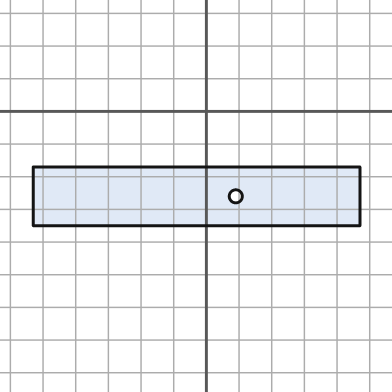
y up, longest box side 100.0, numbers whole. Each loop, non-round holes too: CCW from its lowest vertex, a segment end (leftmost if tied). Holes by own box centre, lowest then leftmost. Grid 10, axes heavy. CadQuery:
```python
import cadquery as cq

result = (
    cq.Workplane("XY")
    .moveTo(-53.0, -35.0)
    .lineTo(47.0, -35.0)
    .lineTo(47.0, -17.0)
    .lineTo(-53.0, -17.0)
    .close()
    .moveTo(9.0, -26.0)
    .circle(2.0)
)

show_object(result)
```